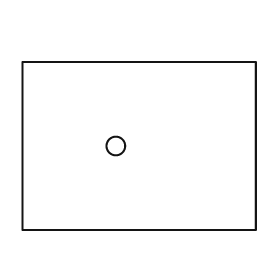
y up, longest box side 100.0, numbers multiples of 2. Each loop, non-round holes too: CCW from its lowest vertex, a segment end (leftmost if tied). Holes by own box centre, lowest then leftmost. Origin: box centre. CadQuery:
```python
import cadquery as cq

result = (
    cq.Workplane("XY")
    .moveTo(-50.0, -36.0)
    .lineTo(50.0, -36.0)
    .lineTo(50.0, 36.0)
    .lineTo(-50.0, 36.0)
    .close()
    .moveTo(-10.0, 0.0)
    .circle(4.0)
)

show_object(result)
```